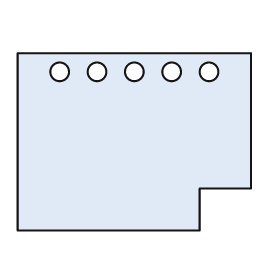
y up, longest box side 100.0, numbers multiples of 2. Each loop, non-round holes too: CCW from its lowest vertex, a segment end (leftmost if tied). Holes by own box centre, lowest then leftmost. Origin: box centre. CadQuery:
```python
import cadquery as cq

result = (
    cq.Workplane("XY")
    .moveTo(-50.0, -38.0)
    .lineTo(28.0, -38.0)
    .lineTo(28.0, -20.0)
    .lineTo(50.0, -20.0)
    .lineTo(50.0, 38.0)
    .lineTo(-50.0, 38.0)
    .close()
    .moveTo(-32.0, 30.0)
    .circle(4.0)
    .moveTo(-16.0, 30.0)
    .circle(4.0)
    .moveTo(0.0, 30.0)
    .circle(4.0)
    .moveTo(16.0, 30.0)
    .circle(4.0)
    .moveTo(32.0, 30.0)
    .circle(4.0)
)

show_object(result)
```